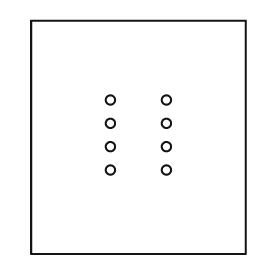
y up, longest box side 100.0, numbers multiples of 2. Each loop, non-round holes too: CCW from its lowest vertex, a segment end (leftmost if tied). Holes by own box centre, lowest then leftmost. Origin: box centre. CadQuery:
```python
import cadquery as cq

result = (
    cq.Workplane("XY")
    .moveTo(-46.0, -50.0)
    .lineTo(46.0, -50.0)
    .lineTo(46.0, 50.0)
    .lineTo(-46.0, 50.0)
    .close()
    .moveTo(-12.0, -14.0)
    .circle(2.0)
    .moveTo(12.0, -14.0)
    .circle(2.0)
    .moveTo(-12.0, -4.0)
    .circle(2.0)
    .moveTo(12.0, -4.0)
    .circle(2.0)
    .moveTo(-12.0, 6.0)
    .circle(2.0)
    .moveTo(12.0, 6.0)
    .circle(2.0)
    .moveTo(-12.0, 16.0)
    .circle(2.0)
    .moveTo(12.0, 16.0)
    .circle(2.0)
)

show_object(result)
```